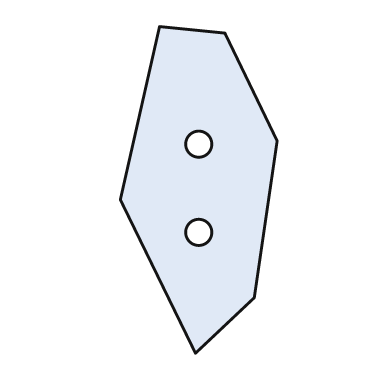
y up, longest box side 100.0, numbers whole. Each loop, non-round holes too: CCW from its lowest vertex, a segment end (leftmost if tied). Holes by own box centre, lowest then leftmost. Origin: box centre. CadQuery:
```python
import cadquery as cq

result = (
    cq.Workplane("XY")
    .moveTo(-1.0, -50.0)
    .lineTo(17.0, -33.0)
    .lineTo(24.0, 15.0)
    .lineTo(8.0, 48.0)
    .lineTo(-12.0, 50.0)
    .lineTo(-24.0, -3.0)
    .close()
    .moveTo(0.0, -13.0)
    .circle(4.0)
    .moveTo(0.0, 14.0)
    .circle(4.0)
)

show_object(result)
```